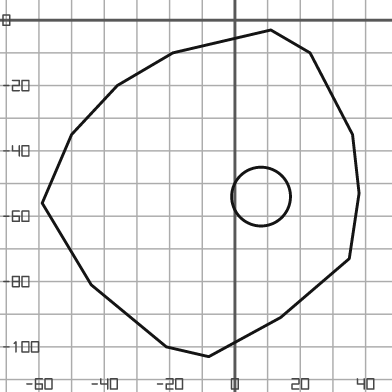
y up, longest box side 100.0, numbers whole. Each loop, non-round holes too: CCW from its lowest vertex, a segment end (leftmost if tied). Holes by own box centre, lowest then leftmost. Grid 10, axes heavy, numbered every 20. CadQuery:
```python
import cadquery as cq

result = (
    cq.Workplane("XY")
    .moveTo(-8.0, -103.0)
    .lineTo(14.0, -91.0)
    .lineTo(35.0, -73.0)
    .lineTo(38.0, -53.0)
    .lineTo(36.0, -35.0)
    .lineTo(23.0, -10.0)
    .lineTo(11.0, -3.0)
    .lineTo(-19.0, -10.0)
    .lineTo(-36.0, -20.0)
    .lineTo(-50.0, -35.0)
    .lineTo(-59.0, -56.0)
    .lineTo(-44.0, -81.0)
    .lineTo(-21.0, -100.0)
    .close()
    .moveTo(8.0, -54.0)
    .circle(9.0)
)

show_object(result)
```